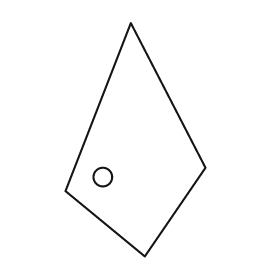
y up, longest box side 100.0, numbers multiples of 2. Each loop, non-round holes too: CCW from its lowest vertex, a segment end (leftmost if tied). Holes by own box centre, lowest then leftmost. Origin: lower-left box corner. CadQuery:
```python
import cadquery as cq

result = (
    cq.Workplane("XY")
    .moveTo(34.0, 0.0)
    .lineTo(60.0, 38.0)
    .lineTo(28.0, 100.0)
    .lineTo(0.0, 28.0)
    .close()
    .moveTo(16.0, 34.0)
    .circle(4.0)
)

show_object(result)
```